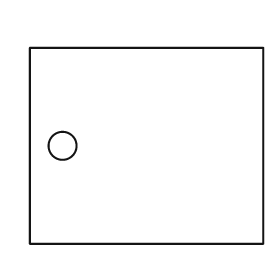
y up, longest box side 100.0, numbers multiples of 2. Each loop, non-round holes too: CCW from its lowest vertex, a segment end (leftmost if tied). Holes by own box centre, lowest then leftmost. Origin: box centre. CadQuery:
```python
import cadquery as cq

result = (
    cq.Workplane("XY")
    .moveTo(-50.0, -42.0)
    .lineTo(50.0, -42.0)
    .lineTo(50.0, 42.0)
    .lineTo(-50.0, 42.0)
    .close()
    .moveTo(-36.0, 0.0)
    .circle(6.0)
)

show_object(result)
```